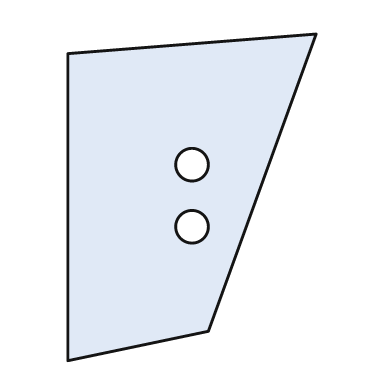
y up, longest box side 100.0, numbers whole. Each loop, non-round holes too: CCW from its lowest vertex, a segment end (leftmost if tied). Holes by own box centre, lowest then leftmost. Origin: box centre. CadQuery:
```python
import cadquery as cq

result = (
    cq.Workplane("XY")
    .moveTo(-38.0, -50.0)
    .lineTo(5.0, -41.0)
    .lineTo(38.0, 50.0)
    .lineTo(-38.0, 44.0)
    .close()
    .moveTo(0.0, -9.0)
    .circle(5.0)
    .moveTo(0.0, 10.0)
    .circle(5.0)
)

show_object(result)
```